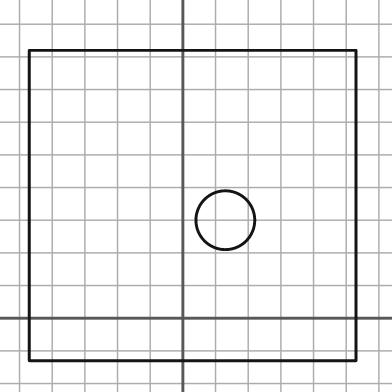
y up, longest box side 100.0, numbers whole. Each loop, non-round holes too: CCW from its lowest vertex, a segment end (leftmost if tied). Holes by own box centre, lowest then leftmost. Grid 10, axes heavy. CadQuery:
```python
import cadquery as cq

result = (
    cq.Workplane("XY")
    .moveTo(-47.0, -13.0)
    .lineTo(53.0, -13.0)
    .lineTo(53.0, 82.0)
    .lineTo(-47.0, 82.0)
    .close()
    .moveTo(13.0, 30.0)
    .circle(9.0)
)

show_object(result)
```